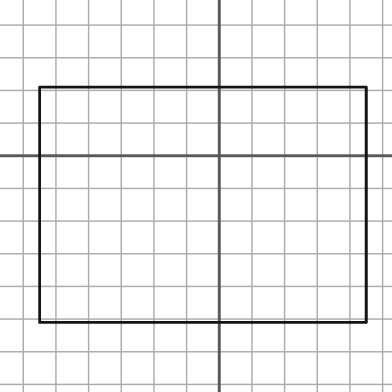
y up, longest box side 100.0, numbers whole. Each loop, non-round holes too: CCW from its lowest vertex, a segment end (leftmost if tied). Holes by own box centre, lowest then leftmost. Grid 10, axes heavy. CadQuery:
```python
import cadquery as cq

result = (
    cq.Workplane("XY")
    .moveTo(-55.0, -51.0)
    .lineTo(45.0, -51.0)
    .lineTo(45.0, 21.0)
    .lineTo(-55.0, 21.0)
    .close()
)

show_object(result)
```